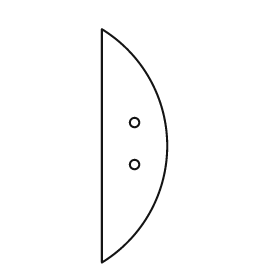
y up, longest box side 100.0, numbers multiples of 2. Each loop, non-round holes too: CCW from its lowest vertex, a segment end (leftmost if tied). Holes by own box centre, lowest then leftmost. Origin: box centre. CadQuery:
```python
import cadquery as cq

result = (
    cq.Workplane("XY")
    .moveTo(-14.0, -50.0)
    .threePointArc((14.0, 0.0), (-14.0, 50.0))
    .close()
    .moveTo(0.0, -8.0)
    .circle(2.0)
    .moveTo(0.0, 10.0)
    .circle(2.0)
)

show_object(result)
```